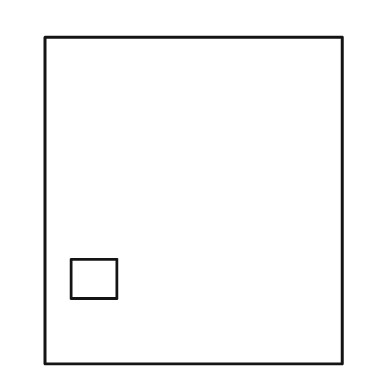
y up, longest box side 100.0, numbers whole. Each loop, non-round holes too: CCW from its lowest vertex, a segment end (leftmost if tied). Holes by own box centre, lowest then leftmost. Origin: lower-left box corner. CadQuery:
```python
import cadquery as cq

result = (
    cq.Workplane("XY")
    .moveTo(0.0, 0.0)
    .lineTo(91.0, 0.0)
    .lineTo(91.0, 100.0)
    .lineTo(0.0, 100.0)
    .close()
    .moveTo(8.0, 20.0)
    .lineTo(22.0, 20.0)
    .lineTo(22.0, 32.0)
    .lineTo(8.0, 32.0)
    .close()
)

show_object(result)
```